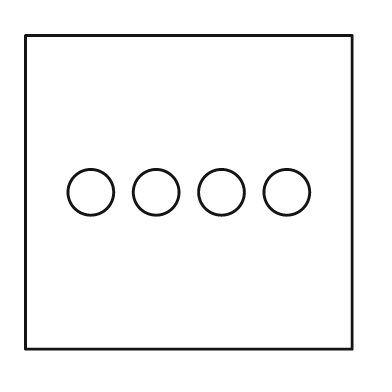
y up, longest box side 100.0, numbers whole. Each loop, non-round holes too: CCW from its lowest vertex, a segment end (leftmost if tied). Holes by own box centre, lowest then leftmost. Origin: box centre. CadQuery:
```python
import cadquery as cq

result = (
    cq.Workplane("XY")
    .moveTo(-50.0, -48.0)
    .lineTo(50.0, -48.0)
    .lineTo(50.0, 48.0)
    .lineTo(-50.0, 48.0)
    .close()
    .moveTo(-30.0, 0.0)
    .circle(7.0)
    .moveTo(-10.0, 0.0)
    .circle(7.0)
    .moveTo(10.0, 0.0)
    .circle(7.0)
    .moveTo(30.0, 0.0)
    .circle(7.0)
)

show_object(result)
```